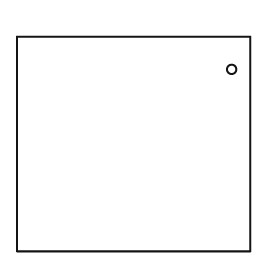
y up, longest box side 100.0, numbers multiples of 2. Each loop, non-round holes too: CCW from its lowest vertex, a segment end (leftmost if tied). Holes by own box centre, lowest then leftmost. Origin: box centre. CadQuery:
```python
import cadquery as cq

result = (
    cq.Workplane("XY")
    .moveTo(-50.0, -46.0)
    .lineTo(50.0, -46.0)
    .lineTo(50.0, 46.0)
    .lineTo(-50.0, 46.0)
    .close()
    .moveTo(42.0, 32.0)
    .circle(2.0)
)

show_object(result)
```